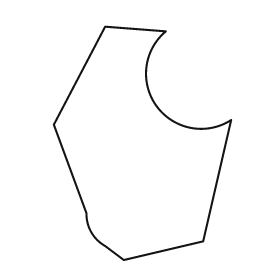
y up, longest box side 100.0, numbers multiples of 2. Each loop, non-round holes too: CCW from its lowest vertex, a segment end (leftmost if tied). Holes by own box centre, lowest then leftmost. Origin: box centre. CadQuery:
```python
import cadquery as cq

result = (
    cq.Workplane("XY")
    .moveTo(-8.0, -50.0)
    .lineTo(26.0, -42.0)
    .lineTo(38.0, 10.0)
    .threePointArc((6.0, 16.0), (10.0, 48.0))
    .lineTo(-16.0, 50.0)
    .lineTo(-38.0, 8.0)
    .lineTo(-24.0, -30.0)
    .threePointArc((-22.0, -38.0), (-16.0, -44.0))
    .close()
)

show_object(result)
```